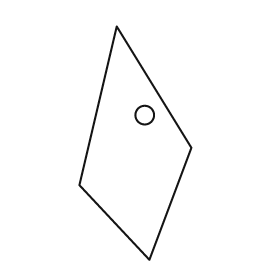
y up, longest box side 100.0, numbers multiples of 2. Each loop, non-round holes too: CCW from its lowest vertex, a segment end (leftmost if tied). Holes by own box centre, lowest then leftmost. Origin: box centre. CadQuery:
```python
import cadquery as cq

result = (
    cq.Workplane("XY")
    .moveTo(6.0, -50.0)
    .lineTo(24.0, -2.0)
    .lineTo(-8.0, 50.0)
    .lineTo(-24.0, -18.0)
    .close()
    .moveTo(4.0, 12.0)
    .circle(4.0)
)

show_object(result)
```